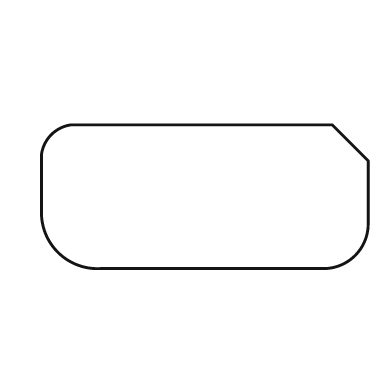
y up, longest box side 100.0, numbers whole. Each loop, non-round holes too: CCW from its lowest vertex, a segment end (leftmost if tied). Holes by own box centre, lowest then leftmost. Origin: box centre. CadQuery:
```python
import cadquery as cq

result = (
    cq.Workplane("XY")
    .moveTo(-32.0, -22.0)
    .lineTo(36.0, -22.0)
    .threePointArc((46.0, -18.0), (50.0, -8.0))
    .lineTo(50.0, 11.0)
    .lineTo(39.0, 22.0)
    .lineTo(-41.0, 22.0)
    .threePointArc((-47.0, 19.0), (-50.0, 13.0))
    .lineTo(-50.0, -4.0)
    .threePointArc((-45.0, -17.0), (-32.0, -22.0))
    .close()
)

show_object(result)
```